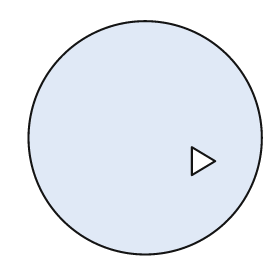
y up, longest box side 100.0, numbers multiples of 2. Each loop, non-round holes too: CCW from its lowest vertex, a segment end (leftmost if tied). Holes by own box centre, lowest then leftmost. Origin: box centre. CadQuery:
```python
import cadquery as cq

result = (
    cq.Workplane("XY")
    .moveTo(0.0, 0.0)
    .circle(50.0)
    .moveTo(20.0, -16.0)
    .lineTo(30.0, -10.0)
    .lineTo(20.0, -4.0)
    .close()
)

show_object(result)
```